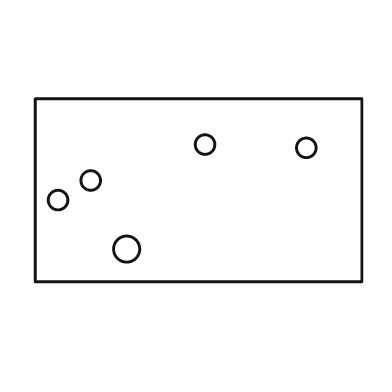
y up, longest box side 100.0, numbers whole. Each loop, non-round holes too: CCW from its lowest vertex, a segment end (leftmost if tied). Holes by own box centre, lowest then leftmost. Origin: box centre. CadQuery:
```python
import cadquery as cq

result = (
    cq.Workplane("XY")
    .moveTo(-50.0, -28.0)
    .lineTo(50.0, -28.0)
    .lineTo(50.0, 28.0)
    .lineTo(-50.0, 28.0)
    .close()
    .moveTo(-22.0, -18.0)
    .circle(4.0)
    .moveTo(-43.0, -3.0)
    .circle(3.0)
    .moveTo(-33.0, 3.0)
    .circle(3.0)
    .moveTo(33.0, 13.0)
    .circle(3.0)
    .moveTo(2.0, 14.0)
    .circle(3.0)
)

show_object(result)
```